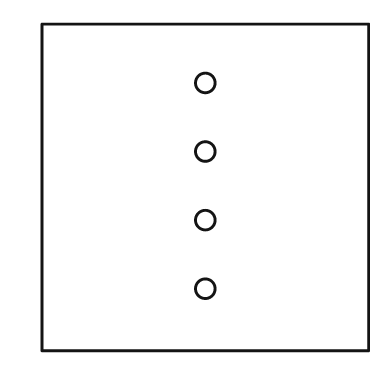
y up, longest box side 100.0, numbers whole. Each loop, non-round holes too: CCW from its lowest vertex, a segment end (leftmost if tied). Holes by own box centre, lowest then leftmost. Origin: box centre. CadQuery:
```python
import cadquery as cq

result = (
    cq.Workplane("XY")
    .moveTo(-50.0, -50.0)
    .lineTo(50.0, -50.0)
    .lineTo(50.0, 50.0)
    .lineTo(-50.0, 50.0)
    .close()
    .moveTo(0.0, -31.0)
    .circle(3.0)
    .moveTo(0.0, -10.0)
    .circle(3.0)
    .moveTo(0.0, 11.0)
    .circle(3.0)
    .moveTo(0.0, 32.0)
    .circle(3.0)
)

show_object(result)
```